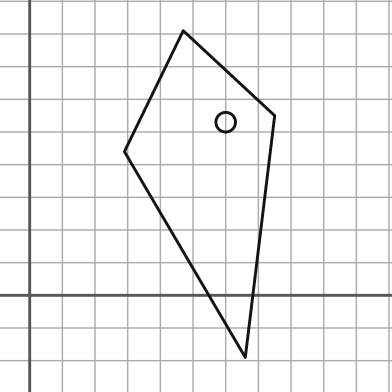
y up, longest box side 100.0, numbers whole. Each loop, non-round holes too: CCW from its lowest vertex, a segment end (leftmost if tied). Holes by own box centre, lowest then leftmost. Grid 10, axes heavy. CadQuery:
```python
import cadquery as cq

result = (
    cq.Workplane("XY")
    .moveTo(66.0, -19.0)
    .lineTo(75.0, 55.0)
    .lineTo(47.0, 81.0)
    .lineTo(29.0, 44.0)
    .close()
    .moveTo(60.0, 53.0)
    .circle(3.0)
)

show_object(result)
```